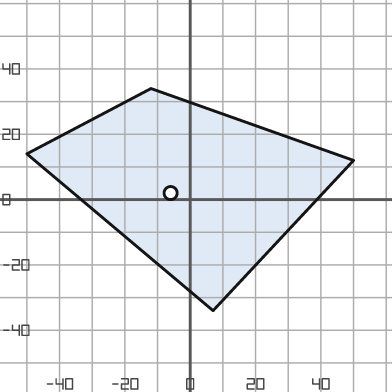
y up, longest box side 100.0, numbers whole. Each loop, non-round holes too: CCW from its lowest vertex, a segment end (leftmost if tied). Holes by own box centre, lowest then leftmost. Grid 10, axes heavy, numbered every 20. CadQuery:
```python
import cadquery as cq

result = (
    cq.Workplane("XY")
    .moveTo(7.0, -34.0)
    .lineTo(50.0, 12.0)
    .lineTo(-12.0, 34.0)
    .lineTo(-50.0, 14.0)
    .close()
    .moveTo(-6.0, 2.0)
    .circle(2.0)
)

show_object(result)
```